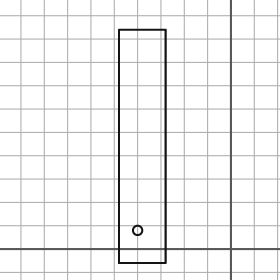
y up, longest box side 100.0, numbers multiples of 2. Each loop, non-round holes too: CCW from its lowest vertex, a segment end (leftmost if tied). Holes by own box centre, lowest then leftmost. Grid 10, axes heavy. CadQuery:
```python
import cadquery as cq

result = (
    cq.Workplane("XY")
    .moveTo(-48.0, -6.0)
    .lineTo(-28.0, -6.0)
    .lineTo(-28.0, 94.0)
    .lineTo(-48.0, 94.0)
    .close()
    .moveTo(-40.0, 8.0)
    .circle(2.0)
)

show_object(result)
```